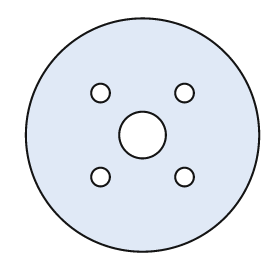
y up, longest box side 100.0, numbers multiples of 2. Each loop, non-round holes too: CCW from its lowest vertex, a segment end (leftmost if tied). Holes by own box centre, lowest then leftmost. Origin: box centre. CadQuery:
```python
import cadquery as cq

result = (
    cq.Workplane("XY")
    .moveTo(0.0, 0.0)
    .circle(50.0)
    .moveTo(-18.0, -18.0)
    .circle(4.0)
    .moveTo(18.0, -18.0)
    .circle(4.0)
    .moveTo(0.0, 0.0)
    .circle(10.0)
    .moveTo(-18.0, 18.0)
    .circle(4.0)
    .moveTo(18.0, 18.0)
    .circle(4.0)
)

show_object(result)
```